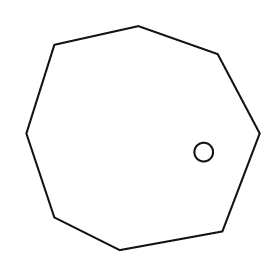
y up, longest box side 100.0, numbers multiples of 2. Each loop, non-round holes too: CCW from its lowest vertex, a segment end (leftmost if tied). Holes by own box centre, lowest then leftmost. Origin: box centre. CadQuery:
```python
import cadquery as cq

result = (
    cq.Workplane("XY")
    .moveTo(-10.0, -48.0)
    .lineTo(34.0, -40.0)
    .lineTo(50.0, 2.0)
    .lineTo(32.0, 36.0)
    .lineTo(-2.0, 48.0)
    .lineTo(-38.0, 40.0)
    .lineTo(-50.0, 2.0)
    .lineTo(-38.0, -34.0)
    .close()
    .moveTo(26.0, -6.0)
    .circle(4.0)
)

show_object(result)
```